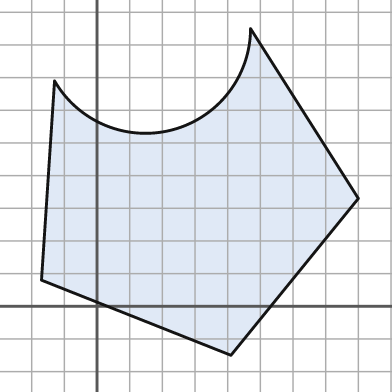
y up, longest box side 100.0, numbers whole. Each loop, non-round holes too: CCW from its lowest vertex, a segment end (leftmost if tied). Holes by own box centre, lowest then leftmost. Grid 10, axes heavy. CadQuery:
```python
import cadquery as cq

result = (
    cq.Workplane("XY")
    .moveTo(41.0, -15.0)
    .lineTo(80.0, 33.0)
    .lineTo(47.0, 85.0)
    .threePointArc((23.0, 54.0), (-13.0, 69.0))
    .lineTo(-17.0, 8.0)
    .close()
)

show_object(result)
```